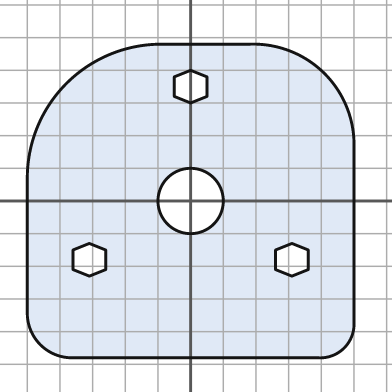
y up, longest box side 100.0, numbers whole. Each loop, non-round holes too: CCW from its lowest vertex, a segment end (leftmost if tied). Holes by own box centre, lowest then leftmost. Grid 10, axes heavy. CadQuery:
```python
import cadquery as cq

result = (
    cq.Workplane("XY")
    .moveTo(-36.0, -48.0)
    .lineTo(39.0, -48.0)
    .threePointArc((47.0, -45.0), (50.0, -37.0))
    .lineTo(50.0, 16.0)
    .threePointArc((41.0, 39.0), (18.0, 48.0))
    .lineTo(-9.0, 48.0)
    .threePointArc((-38.0, 36.0), (-50.0, 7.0))
    .lineTo(-50.0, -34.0)
    .threePointArc((-46.0, -44.0), (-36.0, -48.0))
    .close()
    .moveTo(-31.0, -23.0)
    .lineTo(-26.0, -21.0)
    .lineTo(-26.0, -15.0)
    .lineTo(-31.0, -13.0)
    .lineTo(-36.0, -15.0)
    .lineTo(-36.0, -21.0)
    .close()
    .moveTo(31.0, -23.0)
    .lineTo(36.0, -21.0)
    .lineTo(36.0, -15.0)
    .lineTo(31.0, -13.0)
    .lineTo(26.0, -15.0)
    .lineTo(26.0, -21.0)
    .close()
    .moveTo(0.0, 0.0)
    .circle(10.0)
    .moveTo(0.0, 30.0)
    .lineTo(5.0, 32.0)
    .lineTo(5.0, 38.0)
    .lineTo(0.0, 40.0)
    .lineTo(-5.0, 38.0)
    .lineTo(-5.0, 32.0)
    .close()
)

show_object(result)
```